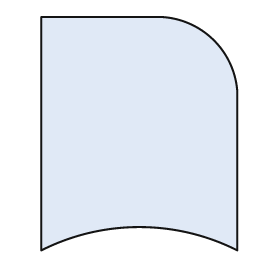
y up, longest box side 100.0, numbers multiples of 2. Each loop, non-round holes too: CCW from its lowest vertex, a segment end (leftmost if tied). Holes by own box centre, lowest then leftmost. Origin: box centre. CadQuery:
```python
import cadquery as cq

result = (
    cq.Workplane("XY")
    .moveTo(-42.0, -50.0)
    .threePointArc((0.0, -40.0), (42.0, -50.0))
    .lineTo(42.0, 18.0)
    .threePointArc((32.0, 40.0), (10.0, 50.0))
    .lineTo(-42.0, 50.0)
    .close()
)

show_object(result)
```